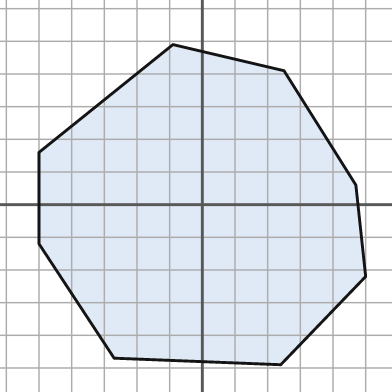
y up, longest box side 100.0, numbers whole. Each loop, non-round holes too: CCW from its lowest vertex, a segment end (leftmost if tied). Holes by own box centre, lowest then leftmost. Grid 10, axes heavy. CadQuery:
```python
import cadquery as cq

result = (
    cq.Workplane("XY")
    .moveTo(24.0, -49.0)
    .lineTo(50.0, -22.0)
    .lineTo(47.0, 6.0)
    .lineTo(25.0, 41.0)
    .lineTo(-9.0, 49.0)
    .lineTo(-50.0, 16.0)
    .lineTo(-50.0, -12.0)
    .lineTo(-27.0, -47.0)
    .close()
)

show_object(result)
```